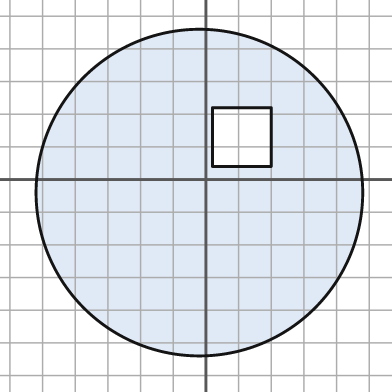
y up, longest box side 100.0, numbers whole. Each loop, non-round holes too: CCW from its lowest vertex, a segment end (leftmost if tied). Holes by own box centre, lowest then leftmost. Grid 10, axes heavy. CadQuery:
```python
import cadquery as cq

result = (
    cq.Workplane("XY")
    .moveTo(-2.0, -4.0)
    .circle(50.0)
    .moveTo(2.0, 4.0)
    .lineTo(20.0, 4.0)
    .lineTo(20.0, 22.0)
    .lineTo(2.0, 22.0)
    .close()
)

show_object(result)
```